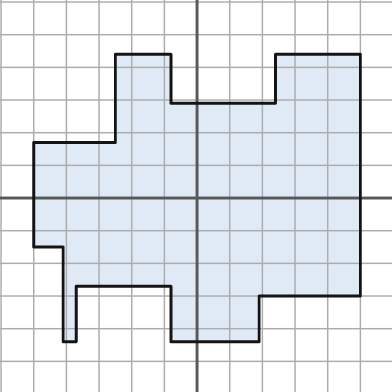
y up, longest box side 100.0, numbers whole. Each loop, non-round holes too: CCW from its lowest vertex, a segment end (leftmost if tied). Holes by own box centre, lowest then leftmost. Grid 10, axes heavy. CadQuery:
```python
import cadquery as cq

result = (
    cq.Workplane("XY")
    .moveTo(-41.0, -44.0)
    .lineTo(-37.0, -44.0)
    .lineTo(-37.0, -27.0)
    .lineTo(-8.0, -27.0)
    .lineTo(-8.0, -44.0)
    .lineTo(19.0, -44.0)
    .lineTo(19.0, -30.0)
    .lineTo(50.0, -30.0)
    .lineTo(50.0, 44.0)
    .lineTo(24.0, 44.0)
    .lineTo(24.0, 29.0)
    .lineTo(-8.0, 29.0)
    .lineTo(-8.0, 44.0)
    .lineTo(-25.0, 44.0)
    .lineTo(-25.0, 17.0)
    .lineTo(-50.0, 17.0)
    .lineTo(-50.0, -15.0)
    .lineTo(-41.0, -15.0)
    .close()
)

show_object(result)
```